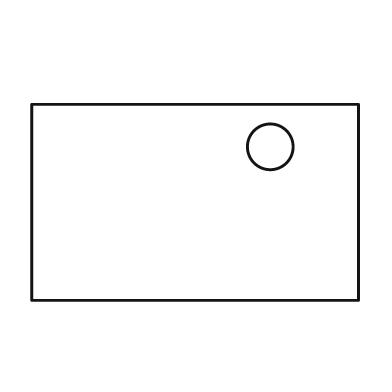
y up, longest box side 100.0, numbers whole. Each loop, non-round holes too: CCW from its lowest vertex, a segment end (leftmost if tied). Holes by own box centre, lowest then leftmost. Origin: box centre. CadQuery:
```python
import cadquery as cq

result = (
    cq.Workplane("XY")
    .moveTo(-50.0, -30.0)
    .lineTo(50.0, -30.0)
    .lineTo(50.0, 30.0)
    .lineTo(-50.0, 30.0)
    .close()
    .moveTo(23.0, 17.0)
    .circle(7.0)
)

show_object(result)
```